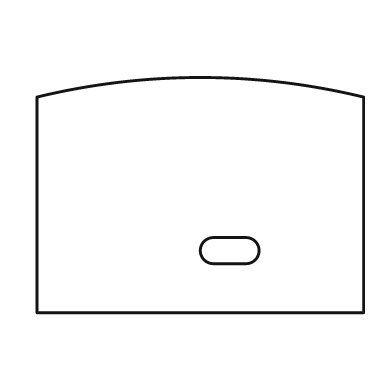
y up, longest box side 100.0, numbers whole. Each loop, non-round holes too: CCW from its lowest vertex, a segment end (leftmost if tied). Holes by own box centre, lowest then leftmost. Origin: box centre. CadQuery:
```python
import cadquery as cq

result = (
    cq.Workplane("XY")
    .moveTo(-50.0, -36.0)
    .lineTo(50.0, -36.0)
    .lineTo(50.0, 30.0)
    .threePointArc((0.0, 36.0), (-50.0, 30.0))
    .close()
    .moveTo(4.0, -21.0)
    .lineTo(14.0, -21.0)
    .threePointArc((18.0, -17.0), (14.0, -13.0))
    .lineTo(4.0, -13.0)
    .threePointArc((0.0, -17.0), (4.0, -21.0))
    .close()
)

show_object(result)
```